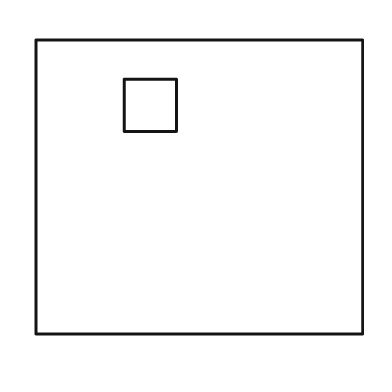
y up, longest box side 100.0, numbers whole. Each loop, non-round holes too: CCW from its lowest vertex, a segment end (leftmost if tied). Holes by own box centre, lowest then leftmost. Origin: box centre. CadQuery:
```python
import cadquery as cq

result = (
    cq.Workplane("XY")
    .moveTo(-50.0, -45.0)
    .lineTo(50.0, -45.0)
    .lineTo(50.0, 45.0)
    .lineTo(-50.0, 45.0)
    .close()
    .moveTo(-23.0, 17.0)
    .lineTo(-7.0, 17.0)
    .lineTo(-7.0, 33.0)
    .lineTo(-23.0, 33.0)
    .close()
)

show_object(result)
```